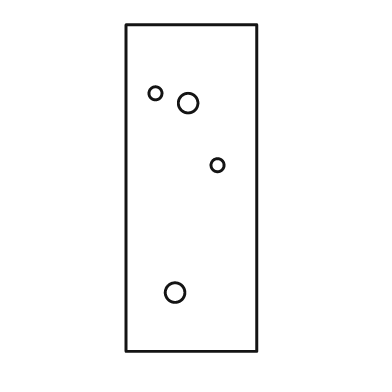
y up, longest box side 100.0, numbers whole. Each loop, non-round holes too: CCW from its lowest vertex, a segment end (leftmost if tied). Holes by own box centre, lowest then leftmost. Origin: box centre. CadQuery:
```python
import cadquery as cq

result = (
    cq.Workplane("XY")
    .moveTo(-20.0, -50.0)
    .lineTo(20.0, -50.0)
    .lineTo(20.0, 50.0)
    .lineTo(-20.0, 50.0)
    .close()
    .moveTo(-5.0, -32.0)
    .circle(3.0)
    .moveTo(8.0, 7.0)
    .circle(2.0)
    .moveTo(-1.0, 26.0)
    .circle(3.0)
    .moveTo(-11.0, 29.0)
    .circle(2.0)
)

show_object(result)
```